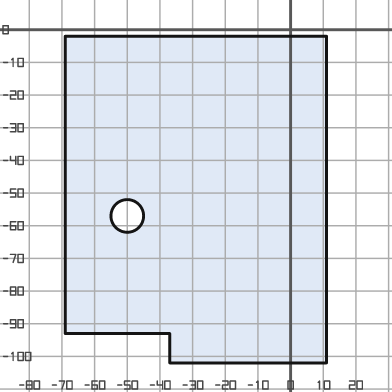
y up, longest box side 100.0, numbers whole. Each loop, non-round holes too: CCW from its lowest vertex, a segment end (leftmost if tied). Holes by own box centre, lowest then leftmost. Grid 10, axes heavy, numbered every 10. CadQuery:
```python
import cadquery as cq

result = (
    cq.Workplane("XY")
    .moveTo(-37.0, -102.0)
    .lineTo(11.0, -102.0)
    .lineTo(11.0, -2.0)
    .lineTo(-69.0, -2.0)
    .lineTo(-69.0, -93.0)
    .lineTo(-37.0, -93.0)
    .close()
    .moveTo(-50.0, -57.0)
    .circle(5.0)
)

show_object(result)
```